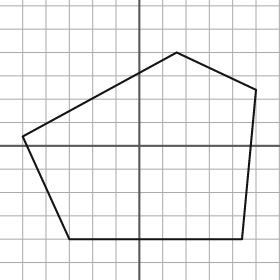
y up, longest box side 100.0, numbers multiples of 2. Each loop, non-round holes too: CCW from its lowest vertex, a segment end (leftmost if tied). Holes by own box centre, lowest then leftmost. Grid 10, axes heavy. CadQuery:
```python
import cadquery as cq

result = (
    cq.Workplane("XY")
    .moveTo(-30.0, -40.0)
    .lineTo(44.0, -40.0)
    .lineTo(50.0, 24.0)
    .lineTo(16.0, 40.0)
    .lineTo(-50.0, 4.0)
    .close()
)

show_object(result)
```